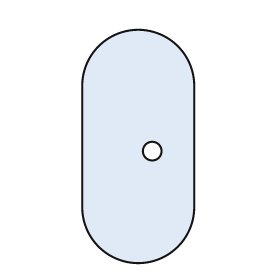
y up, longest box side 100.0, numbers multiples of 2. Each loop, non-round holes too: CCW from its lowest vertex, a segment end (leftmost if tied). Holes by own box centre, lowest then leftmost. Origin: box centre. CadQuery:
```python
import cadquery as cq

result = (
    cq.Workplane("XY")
    .moveTo(-24.0, -26.0)
    .threePointArc((0.0, -50.0), (24.0, -26.0))
    .lineTo(24.0, 26.0)
    .threePointArc((0.0, 50.0), (-24.0, 26.0))
    .close()
    .moveTo(6.0, -2.0)
    .circle(4.0)
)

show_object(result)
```